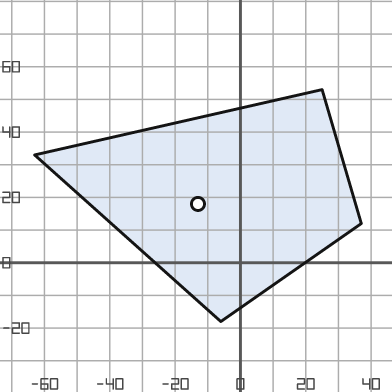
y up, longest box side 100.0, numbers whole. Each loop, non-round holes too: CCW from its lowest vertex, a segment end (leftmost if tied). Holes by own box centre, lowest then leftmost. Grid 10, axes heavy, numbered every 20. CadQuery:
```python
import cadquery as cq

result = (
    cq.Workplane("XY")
    .moveTo(-6.0, -18.0)
    .lineTo(37.0, 12.0)
    .lineTo(25.0, 53.0)
    .lineTo(-63.0, 33.0)
    .close()
    .moveTo(-13.0, 18.0)
    .circle(2.0)
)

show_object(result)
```